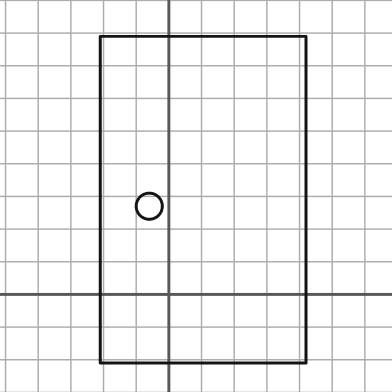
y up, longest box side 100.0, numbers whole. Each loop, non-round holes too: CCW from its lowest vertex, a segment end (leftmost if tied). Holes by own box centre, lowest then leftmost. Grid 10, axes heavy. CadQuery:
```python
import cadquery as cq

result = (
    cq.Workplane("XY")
    .moveTo(-21.0, -21.0)
    .lineTo(42.0, -21.0)
    .lineTo(42.0, 79.0)
    .lineTo(-21.0, 79.0)
    .close()
    .moveTo(-6.0, 27.0)
    .circle(4.0)
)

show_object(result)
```